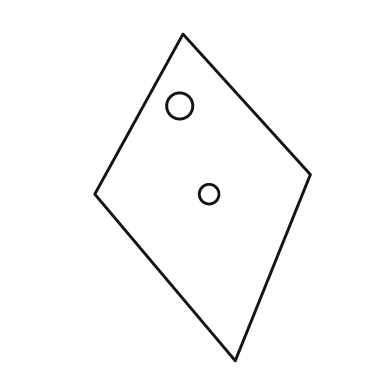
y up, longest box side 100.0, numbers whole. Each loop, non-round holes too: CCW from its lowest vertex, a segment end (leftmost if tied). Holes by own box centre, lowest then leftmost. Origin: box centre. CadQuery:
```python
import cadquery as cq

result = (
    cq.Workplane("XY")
    .moveTo(10.0, -50.0)
    .lineTo(33.0, 7.0)
    .lineTo(-6.0, 50.0)
    .lineTo(-33.0, 1.0)
    .close()
    .moveTo(2.0, 1.0)
    .circle(3.0)
    .moveTo(-7.0, 28.0)
    .circle(4.0)
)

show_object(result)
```